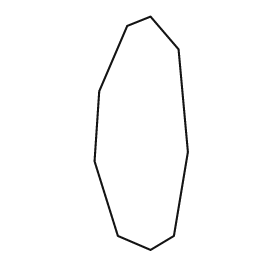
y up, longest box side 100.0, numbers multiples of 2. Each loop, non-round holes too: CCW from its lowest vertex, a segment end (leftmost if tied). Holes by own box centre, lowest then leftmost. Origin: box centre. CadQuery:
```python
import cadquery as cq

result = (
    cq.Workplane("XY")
    .moveTo(4.0, -50.0)
    .lineTo(14.0, -44.0)
    .lineTo(20.0, -8.0)
    .lineTo(16.0, 36.0)
    .lineTo(4.0, 50.0)
    .lineTo(-6.0, 46.0)
    .lineTo(-18.0, 18.0)
    .lineTo(-20.0, -12.0)
    .lineTo(-10.0, -44.0)
    .close()
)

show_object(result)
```